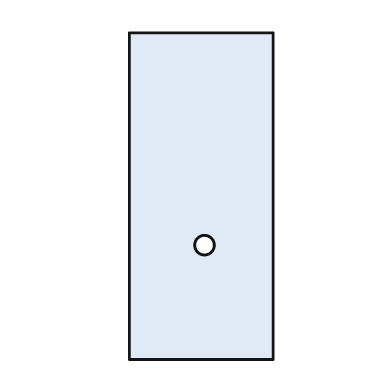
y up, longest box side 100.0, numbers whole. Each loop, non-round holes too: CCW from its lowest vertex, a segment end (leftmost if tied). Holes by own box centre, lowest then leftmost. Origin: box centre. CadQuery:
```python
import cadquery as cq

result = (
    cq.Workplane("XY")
    .moveTo(-22.0, -50.0)
    .lineTo(22.0, -50.0)
    .lineTo(22.0, 50.0)
    .lineTo(-22.0, 50.0)
    .close()
    .moveTo(1.0, -15.0)
    .circle(3.0)
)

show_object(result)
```